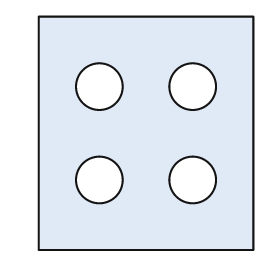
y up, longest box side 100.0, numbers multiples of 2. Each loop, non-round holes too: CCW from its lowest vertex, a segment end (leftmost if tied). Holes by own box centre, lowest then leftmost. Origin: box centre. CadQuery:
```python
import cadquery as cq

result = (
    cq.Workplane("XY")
    .moveTo(-46.0, -50.0)
    .lineTo(46.0, -50.0)
    .lineTo(46.0, 50.0)
    .lineTo(-46.0, 50.0)
    .close()
    .moveTo(-20.0, -20.0)
    .circle(10.0)
    .moveTo(20.0, -20.0)
    .circle(10.0)
    .moveTo(-20.0, 20.0)
    .circle(10.0)
    .moveTo(20.0, 20.0)
    .circle(10.0)
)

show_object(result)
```